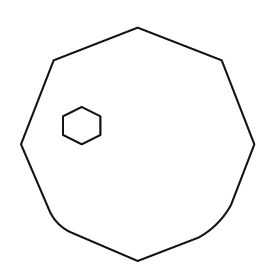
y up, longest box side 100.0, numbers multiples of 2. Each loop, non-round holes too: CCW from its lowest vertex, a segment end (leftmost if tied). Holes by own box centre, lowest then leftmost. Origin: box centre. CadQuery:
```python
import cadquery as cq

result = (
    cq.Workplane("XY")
    .moveTo(0.0, -50.0)
    .lineTo(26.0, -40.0)
    .threePointArc((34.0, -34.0), (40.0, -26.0))
    .lineTo(50.0, 0.0)
    .lineTo(36.0, 36.0)
    .lineTo(0.0, 50.0)
    .lineTo(-36.0, 36.0)
    .lineTo(-50.0, 0.0)
    .lineTo(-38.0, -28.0)
    .threePointArc((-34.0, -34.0), (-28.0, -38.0))
    .close()
    .moveTo(-24.0, 0.0)
    .lineTo(-16.0, 4.0)
    .lineTo(-16.0, 12.0)
    .lineTo(-24.0, 16.0)
    .lineTo(-32.0, 12.0)
    .lineTo(-32.0, 4.0)
    .close()
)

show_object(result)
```